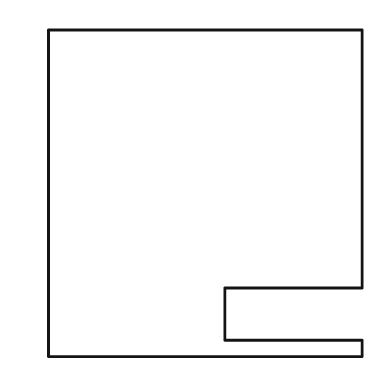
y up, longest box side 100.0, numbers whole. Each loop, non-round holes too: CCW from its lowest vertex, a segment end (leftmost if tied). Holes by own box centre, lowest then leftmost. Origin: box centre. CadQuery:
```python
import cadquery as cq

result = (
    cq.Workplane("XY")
    .moveTo(-48.0, -50.0)
    .lineTo(48.0, -50.0)
    .lineTo(48.0, -45.0)
    .lineTo(6.0, -45.0)
    .lineTo(6.0, -29.0)
    .lineTo(48.0, -29.0)
    .lineTo(48.0, 50.0)
    .lineTo(-48.0, 50.0)
    .close()
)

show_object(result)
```